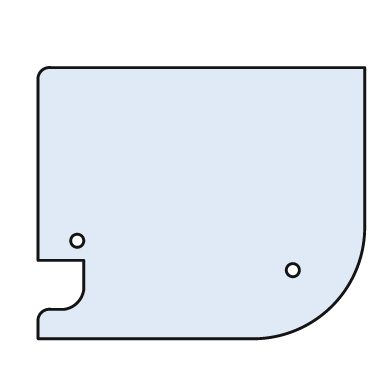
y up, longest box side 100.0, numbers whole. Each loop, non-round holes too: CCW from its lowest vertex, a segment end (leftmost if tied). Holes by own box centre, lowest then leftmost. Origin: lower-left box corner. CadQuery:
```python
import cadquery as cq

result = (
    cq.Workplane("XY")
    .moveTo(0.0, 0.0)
    .lineTo(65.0, 0.0)
    .threePointArc((90.0, 10.0), (100.0, 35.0))
    .lineTo(100.0, 83.0)
    .lineTo(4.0, 83.0)
    .threePointArc((1.0, 82.0), (0.0, 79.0))
    .lineTo(0.0, 24.0)
    .lineTo(14.0, 24.0)
    .lineTo(14.0, 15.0)
    .threePointArc((12.0, 11.0), (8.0, 9.0))
    .lineTo(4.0, 9.0)
    .threePointArc((1.0, 8.0), (0.0, 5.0))
    .close()
    .moveTo(78.0, 21.0)
    .circle(2.0)
    .moveTo(12.0, 30.0)
    .circle(2.0)
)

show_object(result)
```